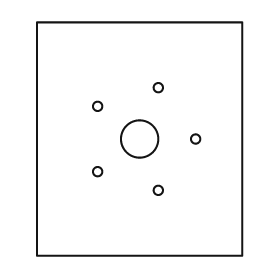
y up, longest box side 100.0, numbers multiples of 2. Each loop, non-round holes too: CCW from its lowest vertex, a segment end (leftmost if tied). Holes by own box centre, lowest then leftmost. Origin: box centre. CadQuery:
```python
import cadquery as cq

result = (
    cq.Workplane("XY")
    .moveTo(-44.0, -50.0)
    .lineTo(44.0, -50.0)
    .lineTo(44.0, 50.0)
    .lineTo(-44.0, 50.0)
    .close()
    .moveTo(8.0, -22.0)
    .circle(2.0)
    .moveTo(-18.0, -14.0)
    .circle(2.0)
    .moveTo(0.0, 0.0)
    .circle(8.0)
    .moveTo(24.0, 0.0)
    .circle(2.0)
    .moveTo(-18.0, 14.0)
    .circle(2.0)
    .moveTo(8.0, 22.0)
    .circle(2.0)
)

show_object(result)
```